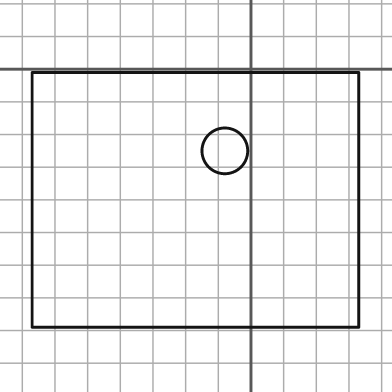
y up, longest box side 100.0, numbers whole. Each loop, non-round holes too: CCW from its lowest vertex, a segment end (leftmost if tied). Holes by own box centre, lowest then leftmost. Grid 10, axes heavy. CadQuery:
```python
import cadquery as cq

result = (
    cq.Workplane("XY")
    .moveTo(-67.0, -79.0)
    .lineTo(33.0, -79.0)
    .lineTo(33.0, -1.0)
    .lineTo(-67.0, -1.0)
    .close()
    .moveTo(-8.0, -25.0)
    .circle(7.0)
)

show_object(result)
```